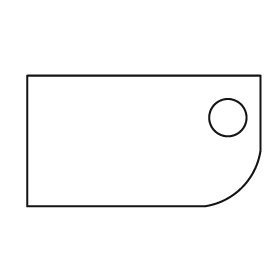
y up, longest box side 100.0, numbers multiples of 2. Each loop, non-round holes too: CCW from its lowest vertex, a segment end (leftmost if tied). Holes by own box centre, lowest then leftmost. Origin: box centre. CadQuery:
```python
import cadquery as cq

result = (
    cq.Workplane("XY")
    .moveTo(-50.0, -28.0)
    .lineTo(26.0, -28.0)
    .threePointArc((42.0, -20.0), (50.0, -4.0))
    .lineTo(50.0, 28.0)
    .lineTo(-50.0, 28.0)
    .close()
    .moveTo(36.0, 10.0)
    .circle(8.0)
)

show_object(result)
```